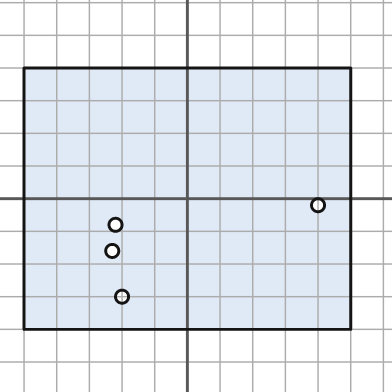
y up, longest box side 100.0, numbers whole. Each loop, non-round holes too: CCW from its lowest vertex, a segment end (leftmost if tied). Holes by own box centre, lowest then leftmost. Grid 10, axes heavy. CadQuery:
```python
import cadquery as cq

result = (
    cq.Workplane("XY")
    .moveTo(-50.0, -40.0)
    .lineTo(50.0, -40.0)
    .lineTo(50.0, 40.0)
    .lineTo(-50.0, 40.0)
    .close()
    .moveTo(-20.0, -30.0)
    .circle(2.0)
    .moveTo(-23.0, -16.0)
    .circle(2.0)
    .moveTo(-22.0, -8.0)
    .circle(2.0)
    .moveTo(40.0, -2.0)
    .circle(2.0)
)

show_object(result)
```